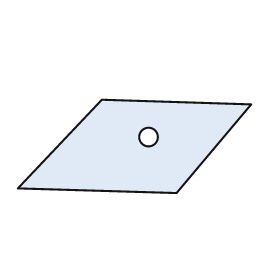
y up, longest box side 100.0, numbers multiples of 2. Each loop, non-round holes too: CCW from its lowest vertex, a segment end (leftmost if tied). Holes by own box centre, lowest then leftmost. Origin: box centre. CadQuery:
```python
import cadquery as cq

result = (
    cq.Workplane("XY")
    .moveTo(18.0, -20.0)
    .lineTo(50.0, 18.0)
    .lineTo(-14.0, 20.0)
    .lineTo(-50.0, -18.0)
    .close()
    .moveTo(6.0, 4.0)
    .circle(4.0)
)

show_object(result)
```